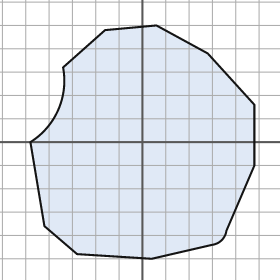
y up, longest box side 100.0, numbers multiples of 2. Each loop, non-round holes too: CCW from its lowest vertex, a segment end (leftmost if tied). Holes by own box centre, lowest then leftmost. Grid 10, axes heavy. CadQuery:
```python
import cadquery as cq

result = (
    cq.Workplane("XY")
    .moveTo(4.0, -50.0)
    .lineTo(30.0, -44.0)
    .threePointArc((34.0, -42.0), (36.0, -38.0))
    .lineTo(48.0, -10.0)
    .lineTo(48.0, 16.0)
    .lineTo(28.0, 38.0)
    .lineTo(6.0, 50.0)
    .lineTo(-16.0, 48.0)
    .lineTo(-34.0, 32.0)
    .threePointArc((-36.0, 14.0), (-48.0, 0.0))
    .lineTo(-42.0, -36.0)
    .lineTo(-28.0, -48.0)
    .close()
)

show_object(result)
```